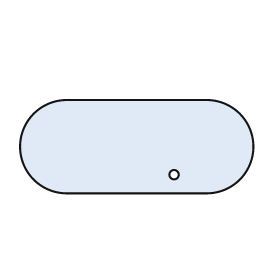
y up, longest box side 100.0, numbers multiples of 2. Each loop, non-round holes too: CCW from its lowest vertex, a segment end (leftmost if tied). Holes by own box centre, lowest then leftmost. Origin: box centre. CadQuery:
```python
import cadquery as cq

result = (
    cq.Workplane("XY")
    .moveTo(-30.0, -20.0)
    .lineTo(30.0, -20.0)
    .threePointArc((50.0, 0.0), (30.0, 20.0))
    .lineTo(-30.0, 20.0)
    .threePointArc((-50.0, 0.0), (-30.0, -20.0))
    .close()
    .moveTo(16.0, -12.0)
    .circle(2.0)
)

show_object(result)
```